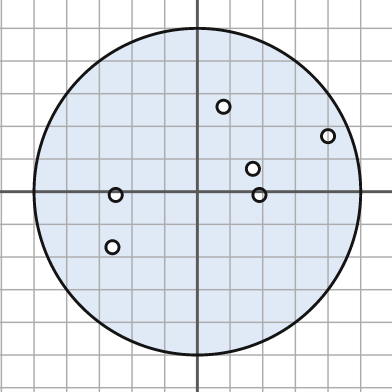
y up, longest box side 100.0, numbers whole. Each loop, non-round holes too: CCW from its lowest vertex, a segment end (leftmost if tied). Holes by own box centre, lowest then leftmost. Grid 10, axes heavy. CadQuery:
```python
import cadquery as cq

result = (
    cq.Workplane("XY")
    .moveTo(0.0, 0.0)
    .circle(50.0)
    .moveTo(-26.0, -17.0)
    .circle(2.0)
    .moveTo(-25.0, -1.0)
    .circle(2.0)
    .moveTo(19.0, -1.0)
    .circle(2.0)
    .moveTo(17.0, 7.0)
    .circle(2.0)
    .moveTo(40.0, 17.0)
    .circle(2.0)
    .moveTo(8.0, 26.0)
    .circle(2.0)
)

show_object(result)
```